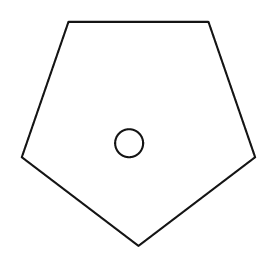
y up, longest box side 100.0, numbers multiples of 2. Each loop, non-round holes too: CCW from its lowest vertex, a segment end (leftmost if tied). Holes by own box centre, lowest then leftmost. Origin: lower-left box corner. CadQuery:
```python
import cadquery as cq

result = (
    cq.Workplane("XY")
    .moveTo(50.0, 0.0)
    .lineTo(100.0, 38.0)
    .lineTo(80.0, 96.0)
    .lineTo(20.0, 96.0)
    .lineTo(0.0, 38.0)
    .close()
    .moveTo(46.0, 44.0)
    .circle(6.0)
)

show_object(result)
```